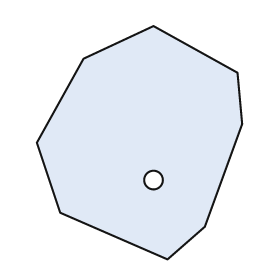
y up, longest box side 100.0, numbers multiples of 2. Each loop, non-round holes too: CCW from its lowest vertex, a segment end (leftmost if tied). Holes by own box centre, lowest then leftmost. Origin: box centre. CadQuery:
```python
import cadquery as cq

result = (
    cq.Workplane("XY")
    .moveTo(12.0, -50.0)
    .lineTo(28.0, -36.0)
    .lineTo(44.0, 8.0)
    .lineTo(42.0, 30.0)
    .lineTo(6.0, 50.0)
    .lineTo(-24.0, 36.0)
    .lineTo(-44.0, 0.0)
    .lineTo(-34.0, -30.0)
    .close()
    .moveTo(6.0, -16.0)
    .circle(4.0)
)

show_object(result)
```